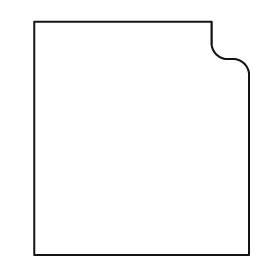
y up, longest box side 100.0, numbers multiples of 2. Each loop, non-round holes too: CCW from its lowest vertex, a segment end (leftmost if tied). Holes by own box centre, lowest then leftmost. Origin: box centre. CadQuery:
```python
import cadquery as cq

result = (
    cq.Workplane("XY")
    .moveTo(-46.0, -50.0)
    .lineTo(46.0, -50.0)
    .lineTo(46.0, 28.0)
    .threePointArc((44.0, 32.0), (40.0, 34.0))
    .lineTo(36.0, 34.0)
    .threePointArc((32.0, 36.0), (30.0, 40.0))
    .lineTo(30.0, 50.0)
    .lineTo(-46.0, 50.0)
    .close()
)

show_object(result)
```